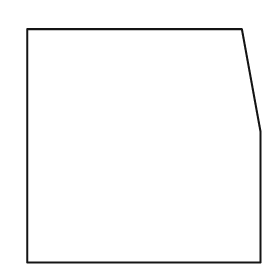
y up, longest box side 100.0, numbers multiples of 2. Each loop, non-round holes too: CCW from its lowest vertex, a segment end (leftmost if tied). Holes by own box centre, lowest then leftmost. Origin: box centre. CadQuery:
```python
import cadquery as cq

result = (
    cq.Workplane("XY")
    .moveTo(-50.0, -50.0)
    .lineTo(50.0, -50.0)
    .lineTo(50.0, 6.0)
    .lineTo(42.0, 50.0)
    .lineTo(-50.0, 50.0)
    .close()
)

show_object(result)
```